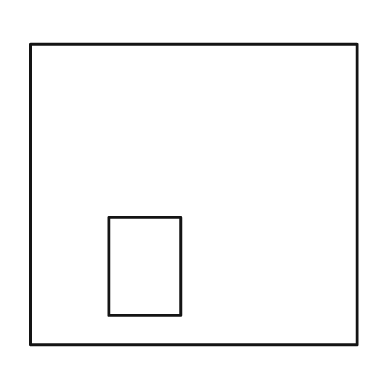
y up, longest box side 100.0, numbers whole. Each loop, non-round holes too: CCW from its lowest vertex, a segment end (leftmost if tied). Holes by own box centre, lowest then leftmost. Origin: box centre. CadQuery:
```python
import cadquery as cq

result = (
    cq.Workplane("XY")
    .moveTo(-50.0, -46.0)
    .lineTo(50.0, -46.0)
    .lineTo(50.0, 46.0)
    .lineTo(-50.0, 46.0)
    .close()
    .moveTo(-26.0, -37.0)
    .lineTo(-4.0, -37.0)
    .lineTo(-4.0, -7.0)
    .lineTo(-26.0, -7.0)
    .close()
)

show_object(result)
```